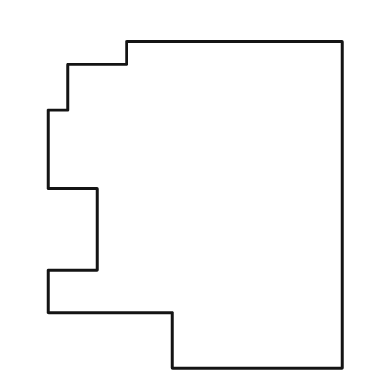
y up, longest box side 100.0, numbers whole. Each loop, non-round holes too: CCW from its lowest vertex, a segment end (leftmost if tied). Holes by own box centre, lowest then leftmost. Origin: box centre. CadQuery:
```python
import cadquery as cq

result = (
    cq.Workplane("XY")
    .moveTo(-7.0, -50.0)
    .lineTo(45.0, -50.0)
    .lineTo(45.0, 50.0)
    .lineTo(-21.0, 50.0)
    .lineTo(-21.0, 43.0)
    .lineTo(-39.0, 43.0)
    .lineTo(-39.0, 29.0)
    .lineTo(-45.0, 29.0)
    .lineTo(-45.0, 5.0)
    .lineTo(-30.0, 5.0)
    .lineTo(-30.0, -20.0)
    .lineTo(-45.0, -20.0)
    .lineTo(-45.0, -33.0)
    .lineTo(-7.0, -33.0)
    .close()
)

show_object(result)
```